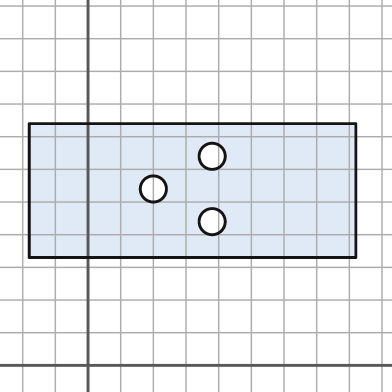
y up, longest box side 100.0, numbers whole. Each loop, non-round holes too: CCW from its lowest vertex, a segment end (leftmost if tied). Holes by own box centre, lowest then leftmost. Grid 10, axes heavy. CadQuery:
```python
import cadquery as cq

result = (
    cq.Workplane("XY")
    .moveTo(-18.0, 33.0)
    .lineTo(82.0, 33.0)
    .lineTo(82.0, 74.0)
    .lineTo(-18.0, 74.0)
    .close()
    .moveTo(38.0, 44.0)
    .circle(4.0)
    .moveTo(20.0, 54.0)
    .circle(4.0)
    .moveTo(38.0, 64.0)
    .circle(4.0)
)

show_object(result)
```